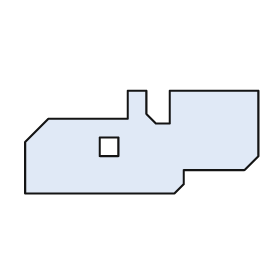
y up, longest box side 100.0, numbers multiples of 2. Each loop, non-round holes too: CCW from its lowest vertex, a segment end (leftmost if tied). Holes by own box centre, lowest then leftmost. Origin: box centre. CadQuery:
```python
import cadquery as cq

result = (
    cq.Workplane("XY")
    .moveTo(-50.0, -22.0)
    .lineTo(14.0, -22.0)
    .lineTo(18.0, -18.0)
    .lineTo(18.0, -12.0)
    .lineTo(44.0, -12.0)
    .lineTo(50.0, -6.0)
    .lineTo(50.0, 22.0)
    .lineTo(12.0, 22.0)
    .lineTo(12.0, 8.0)
    .lineTo(6.0, 8.0)
    .lineTo(2.0, 12.0)
    .lineTo(2.0, 22.0)
    .lineTo(-6.0, 22.0)
    .lineTo(-6.0, 10.0)
    .lineTo(-40.0, 10.0)
    .lineTo(-50.0, 0.0)
    .close()
    .moveTo(-18.0, -6.0)
    .lineTo(-10.0, -6.0)
    .lineTo(-10.0, 2.0)
    .lineTo(-18.0, 2.0)
    .close()
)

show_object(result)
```